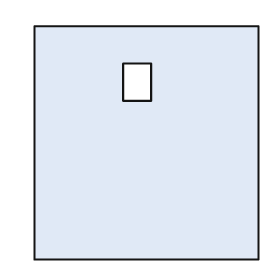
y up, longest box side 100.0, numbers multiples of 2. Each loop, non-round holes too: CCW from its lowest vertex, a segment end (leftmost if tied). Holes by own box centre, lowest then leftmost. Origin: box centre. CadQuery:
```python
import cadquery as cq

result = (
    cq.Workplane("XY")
    .moveTo(-48.0, -50.0)
    .lineTo(48.0, -50.0)
    .lineTo(48.0, 50.0)
    .lineTo(-48.0, 50.0)
    .close()
    .moveTo(-10.0, 18.0)
    .lineTo(2.0, 18.0)
    .lineTo(2.0, 34.0)
    .lineTo(-10.0, 34.0)
    .close()
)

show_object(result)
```